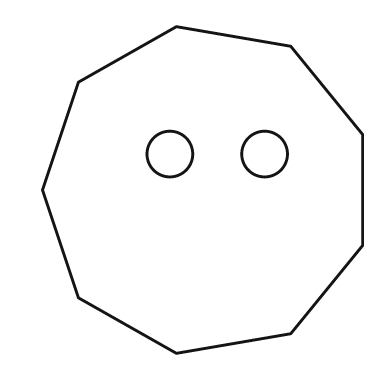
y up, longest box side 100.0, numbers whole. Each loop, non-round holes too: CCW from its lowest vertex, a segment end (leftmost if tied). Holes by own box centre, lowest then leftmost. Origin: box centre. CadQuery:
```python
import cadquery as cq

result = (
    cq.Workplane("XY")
    .moveTo(-8.0, -50.0)
    .lineTo(27.0, -44.0)
    .lineTo(49.0, -17.0)
    .lineTo(49.0, 17.0)
    .lineTo(27.0, 44.0)
    .lineTo(-8.0, 50.0)
    .lineTo(-38.0, 33.0)
    .lineTo(-49.0, 0.0)
    .lineTo(-38.0, -33.0)
    .close()
    .moveTo(-10.0, 11.0)
    .circle(7.0)
    .moveTo(19.0, 11.0)
    .circle(7.0)
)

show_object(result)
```